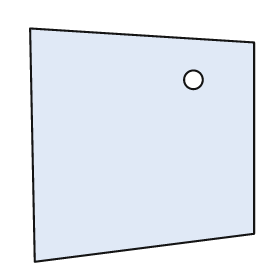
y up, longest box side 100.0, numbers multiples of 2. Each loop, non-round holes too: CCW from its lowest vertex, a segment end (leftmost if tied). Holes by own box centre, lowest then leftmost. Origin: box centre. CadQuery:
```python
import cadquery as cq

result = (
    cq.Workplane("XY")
    .moveTo(-46.0, -50.0)
    .lineTo(48.0, -38.0)
    .lineTo(48.0, 44.0)
    .lineTo(-48.0, 50.0)
    .close()
    .moveTo(22.0, 28.0)
    .circle(4.0)
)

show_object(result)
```